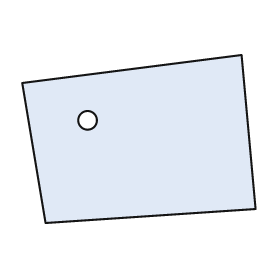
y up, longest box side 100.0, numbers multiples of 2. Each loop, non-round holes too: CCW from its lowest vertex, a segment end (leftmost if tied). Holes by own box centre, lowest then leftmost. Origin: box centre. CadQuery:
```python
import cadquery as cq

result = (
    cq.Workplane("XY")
    .moveTo(-40.0, -36.0)
    .lineTo(50.0, -30.0)
    .lineTo(44.0, 36.0)
    .lineTo(-50.0, 24.0)
    .close()
    .moveTo(-22.0, 8.0)
    .circle(4.0)
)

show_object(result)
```